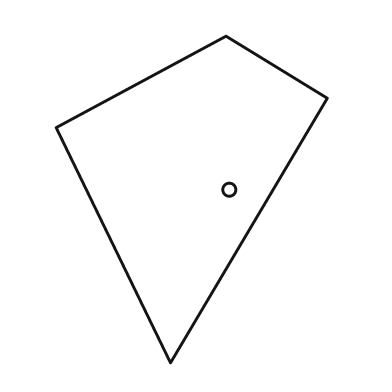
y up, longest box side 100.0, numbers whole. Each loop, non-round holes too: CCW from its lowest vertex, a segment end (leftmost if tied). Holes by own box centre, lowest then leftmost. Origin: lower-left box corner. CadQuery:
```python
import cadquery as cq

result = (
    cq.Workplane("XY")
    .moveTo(35.0, 0.0)
    .lineTo(83.0, 81.0)
    .lineTo(52.0, 100.0)
    .lineTo(0.0, 72.0)
    .close()
    .moveTo(53.0, 53.0)
    .circle(2.0)
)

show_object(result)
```